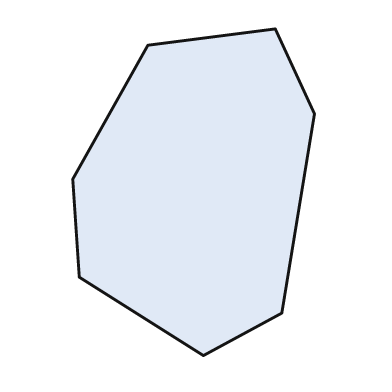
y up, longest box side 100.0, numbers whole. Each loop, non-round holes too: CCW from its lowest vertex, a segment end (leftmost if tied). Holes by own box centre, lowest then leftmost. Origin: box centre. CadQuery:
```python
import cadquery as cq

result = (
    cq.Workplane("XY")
    .moveTo(3.0, -50.0)
    .lineTo(27.0, -37.0)
    .lineTo(37.0, 24.0)
    .lineTo(25.0, 50.0)
    .lineTo(-14.0, 45.0)
    .lineTo(-37.0, 4.0)
    .lineTo(-35.0, -26.0)
    .close()
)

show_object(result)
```